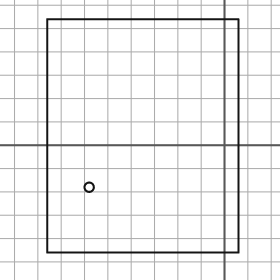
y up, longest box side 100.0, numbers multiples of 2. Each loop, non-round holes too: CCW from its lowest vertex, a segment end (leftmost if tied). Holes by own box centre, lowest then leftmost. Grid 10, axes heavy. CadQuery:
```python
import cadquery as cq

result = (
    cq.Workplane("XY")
    .moveTo(-76.0, -46.0)
    .lineTo(6.0, -46.0)
    .lineTo(6.0, 54.0)
    .lineTo(-76.0, 54.0)
    .close()
    .moveTo(-58.0, -18.0)
    .circle(2.0)
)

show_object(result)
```